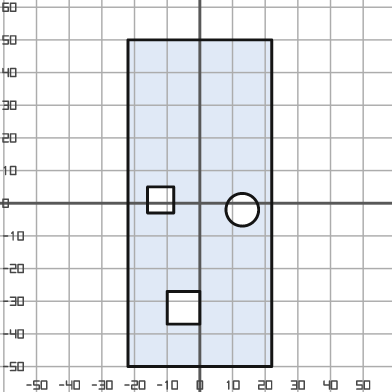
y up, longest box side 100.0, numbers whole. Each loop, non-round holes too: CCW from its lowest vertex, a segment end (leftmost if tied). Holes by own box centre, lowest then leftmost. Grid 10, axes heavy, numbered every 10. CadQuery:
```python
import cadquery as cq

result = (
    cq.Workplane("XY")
    .moveTo(-22.0, -50.0)
    .lineTo(22.0, -50.0)
    .lineTo(22.0, 50.0)
    .lineTo(-22.0, 50.0)
    .close()
    .moveTo(-10.0, -37.0)
    .lineTo(0.0, -37.0)
    .lineTo(0.0, -27.0)
    .lineTo(-10.0, -27.0)
    .close()
    .moveTo(13.0, -2.0)
    .circle(5.0)
    .moveTo(-16.0, -3.0)
    .lineTo(-8.0, -3.0)
    .lineTo(-8.0, 5.0)
    .lineTo(-16.0, 5.0)
    .close()
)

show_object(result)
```